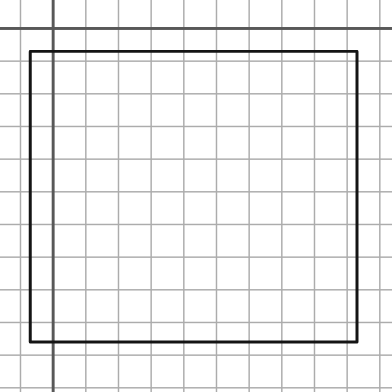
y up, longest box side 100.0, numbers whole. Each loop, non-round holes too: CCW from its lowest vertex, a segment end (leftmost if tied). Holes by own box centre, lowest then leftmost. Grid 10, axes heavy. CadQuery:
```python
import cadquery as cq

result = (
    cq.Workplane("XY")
    .moveTo(-7.0, -96.0)
    .lineTo(93.0, -96.0)
    .lineTo(93.0, -7.0)
    .lineTo(-7.0, -7.0)
    .close()
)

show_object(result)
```